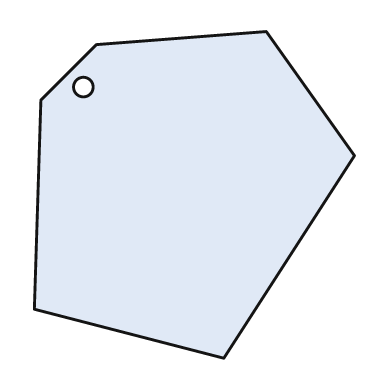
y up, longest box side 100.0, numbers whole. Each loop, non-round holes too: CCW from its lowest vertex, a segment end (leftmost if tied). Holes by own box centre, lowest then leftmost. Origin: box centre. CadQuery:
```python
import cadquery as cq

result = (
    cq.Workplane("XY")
    .moveTo(9.0, -50.0)
    .lineTo(49.0, 12.0)
    .lineTo(22.0, 50.0)
    .lineTo(-30.0, 46.0)
    .lineTo(-47.0, 29.0)
    .lineTo(-49.0, -35.0)
    .close()
    .moveTo(-34.0, 33.0)
    .circle(3.0)
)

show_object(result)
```